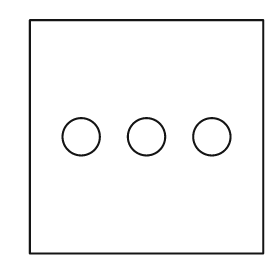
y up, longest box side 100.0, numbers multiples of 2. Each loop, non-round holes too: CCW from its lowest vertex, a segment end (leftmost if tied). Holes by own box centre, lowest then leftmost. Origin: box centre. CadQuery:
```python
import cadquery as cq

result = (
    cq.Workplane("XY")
    .moveTo(-50.0, -50.0)
    .lineTo(50.0, -50.0)
    .lineTo(50.0, 50.0)
    .lineTo(-50.0, 50.0)
    .close()
    .moveTo(-28.0, 0.0)
    .circle(8.0)
    .moveTo(0.0, 0.0)
    .circle(8.0)
    .moveTo(28.0, 0.0)
    .circle(8.0)
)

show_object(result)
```